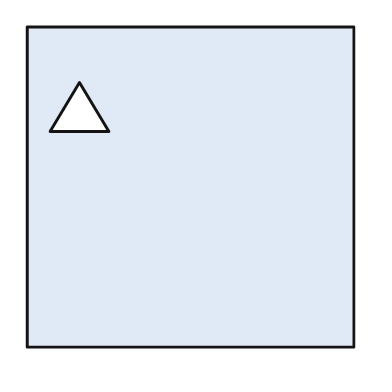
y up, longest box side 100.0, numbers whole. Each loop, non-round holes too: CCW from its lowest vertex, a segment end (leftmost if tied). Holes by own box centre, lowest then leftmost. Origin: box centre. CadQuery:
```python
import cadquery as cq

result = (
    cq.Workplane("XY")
    .moveTo(-50.0, -49.0)
    .lineTo(50.0, -49.0)
    .lineTo(50.0, 49.0)
    .lineTo(-50.0, 49.0)
    .close()
    .moveTo(-43.0, 17.0)
    .lineTo(-25.0, 17.0)
    .lineTo(-34.0, 32.0)
    .close()
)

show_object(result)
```